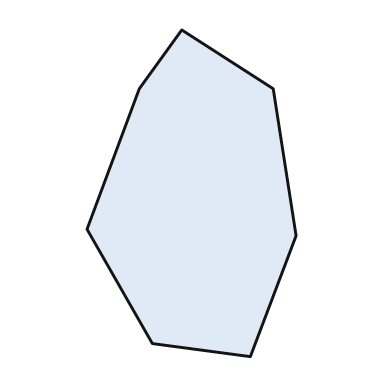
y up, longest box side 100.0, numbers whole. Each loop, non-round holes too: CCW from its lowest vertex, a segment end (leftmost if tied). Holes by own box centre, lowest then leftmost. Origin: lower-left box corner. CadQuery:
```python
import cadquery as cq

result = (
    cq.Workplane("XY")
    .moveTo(50.0, 0.0)
    .lineTo(64.0, 37.0)
    .lineTo(57.0, 82.0)
    .lineTo(29.0, 100.0)
    .lineTo(16.0, 82.0)
    .lineTo(0.0, 39.0)
    .lineTo(20.0, 4.0)
    .close()
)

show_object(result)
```